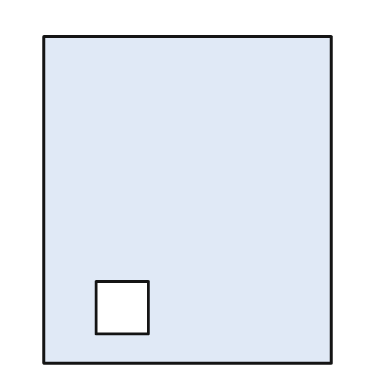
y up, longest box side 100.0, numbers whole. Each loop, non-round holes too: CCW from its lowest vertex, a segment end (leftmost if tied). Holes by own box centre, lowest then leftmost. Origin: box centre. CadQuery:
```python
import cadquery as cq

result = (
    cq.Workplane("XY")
    .moveTo(-44.0, -50.0)
    .lineTo(44.0, -50.0)
    .lineTo(44.0, 50.0)
    .lineTo(-44.0, 50.0)
    .close()
    .moveTo(-28.0, -41.0)
    .lineTo(-12.0, -41.0)
    .lineTo(-12.0, -25.0)
    .lineTo(-28.0, -25.0)
    .close()
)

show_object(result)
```